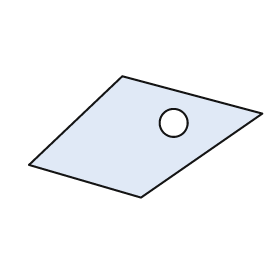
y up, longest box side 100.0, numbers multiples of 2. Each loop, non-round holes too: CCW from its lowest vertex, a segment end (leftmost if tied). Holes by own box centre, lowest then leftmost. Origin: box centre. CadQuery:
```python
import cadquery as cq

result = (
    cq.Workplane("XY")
    .moveTo(-2.0, -26.0)
    .lineTo(50.0, 10.0)
    .lineTo(-10.0, 26.0)
    .lineTo(-50.0, -12.0)
    .close()
    .moveTo(12.0, 6.0)
    .circle(6.0)
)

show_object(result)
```